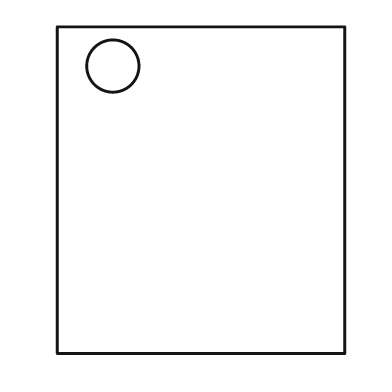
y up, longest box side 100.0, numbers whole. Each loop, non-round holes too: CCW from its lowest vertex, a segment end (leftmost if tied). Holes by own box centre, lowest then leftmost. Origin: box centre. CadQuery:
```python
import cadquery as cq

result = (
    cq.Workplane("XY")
    .moveTo(-44.0, -50.0)
    .lineTo(44.0, -50.0)
    .lineTo(44.0, 50.0)
    .lineTo(-44.0, 50.0)
    .close()
    .moveTo(-27.0, 38.0)
    .circle(8.0)
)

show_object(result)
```